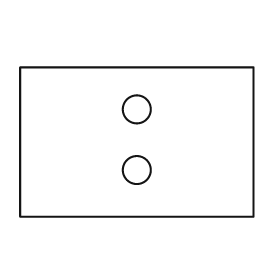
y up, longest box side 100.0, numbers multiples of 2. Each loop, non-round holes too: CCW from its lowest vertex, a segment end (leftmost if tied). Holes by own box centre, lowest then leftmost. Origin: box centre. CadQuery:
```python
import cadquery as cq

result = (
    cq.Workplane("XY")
    .moveTo(-50.0, -32.0)
    .lineTo(50.0, -32.0)
    .lineTo(50.0, 32.0)
    .lineTo(-50.0, 32.0)
    .close()
    .moveTo(0.0, -12.0)
    .circle(6.0)
    .moveTo(0.0, 14.0)
    .circle(6.0)
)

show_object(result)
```